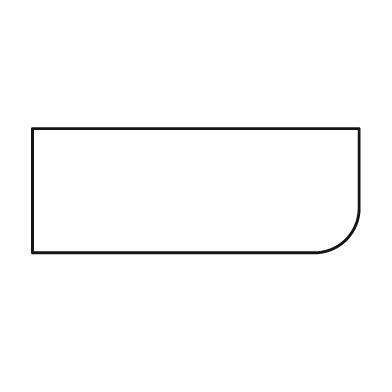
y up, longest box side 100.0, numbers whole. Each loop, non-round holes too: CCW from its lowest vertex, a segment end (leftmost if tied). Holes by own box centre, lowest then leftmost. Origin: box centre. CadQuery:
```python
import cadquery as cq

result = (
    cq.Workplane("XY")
    .moveTo(-50.0, -19.0)
    .lineTo(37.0, -19.0)
    .threePointArc((46.0, -15.0), (50.0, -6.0))
    .lineTo(50.0, 19.0)
    .lineTo(-50.0, 19.0)
    .close()
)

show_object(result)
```